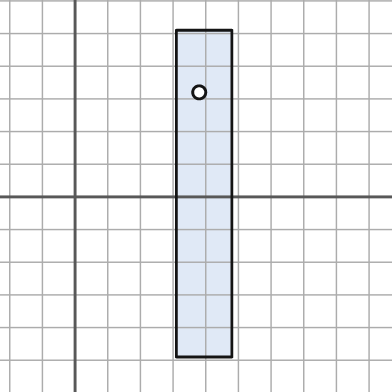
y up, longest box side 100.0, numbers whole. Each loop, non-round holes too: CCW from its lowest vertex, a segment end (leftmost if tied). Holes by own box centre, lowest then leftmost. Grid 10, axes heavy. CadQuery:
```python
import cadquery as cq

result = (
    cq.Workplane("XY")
    .moveTo(31.0, -49.0)
    .lineTo(48.0, -49.0)
    .lineTo(48.0, 51.0)
    .lineTo(31.0, 51.0)
    .close()
    .moveTo(38.0, 32.0)
    .circle(2.0)
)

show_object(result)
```